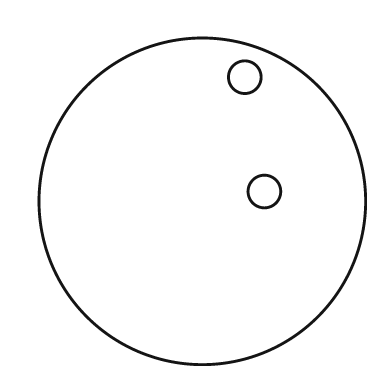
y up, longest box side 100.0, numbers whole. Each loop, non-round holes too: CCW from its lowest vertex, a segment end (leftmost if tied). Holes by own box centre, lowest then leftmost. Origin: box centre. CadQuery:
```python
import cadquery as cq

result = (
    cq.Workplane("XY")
    .moveTo(0.0, 0.0)
    .circle(50.0)
    .moveTo(19.0, 3.0)
    .circle(5.0)
    .moveTo(13.0, 38.0)
    .circle(5.0)
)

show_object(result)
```